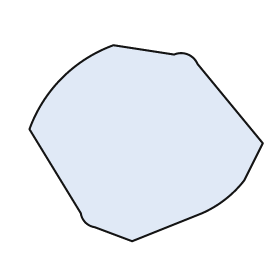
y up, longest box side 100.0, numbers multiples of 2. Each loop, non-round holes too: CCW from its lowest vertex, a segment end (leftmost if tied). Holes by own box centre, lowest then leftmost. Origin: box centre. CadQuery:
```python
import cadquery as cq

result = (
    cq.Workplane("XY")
    .moveTo(-6.0, -42.0)
    .lineTo(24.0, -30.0)
    .threePointArc((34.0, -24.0), (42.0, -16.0))
    .lineTo(50.0, 0.0)
    .lineTo(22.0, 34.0)
    .threePointArc((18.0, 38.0), (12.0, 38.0))
    .lineTo(-14.0, 42.0)
    .threePointArc((-36.0, 28.0), (-50.0, 6.0))
    .lineTo(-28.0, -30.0)
    .threePointArc((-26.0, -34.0), (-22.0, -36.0))
    .close()
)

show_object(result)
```